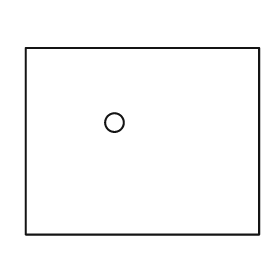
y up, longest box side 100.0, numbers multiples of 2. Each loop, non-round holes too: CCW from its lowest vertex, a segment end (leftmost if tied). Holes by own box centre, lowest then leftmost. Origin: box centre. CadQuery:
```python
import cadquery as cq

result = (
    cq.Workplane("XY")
    .moveTo(-50.0, -40.0)
    .lineTo(50.0, -40.0)
    .lineTo(50.0, 40.0)
    .lineTo(-50.0, 40.0)
    .close()
    .moveTo(-12.0, 8.0)
    .circle(4.0)
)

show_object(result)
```